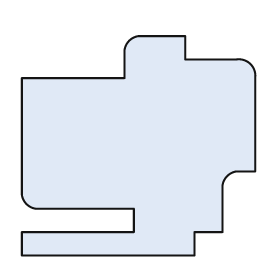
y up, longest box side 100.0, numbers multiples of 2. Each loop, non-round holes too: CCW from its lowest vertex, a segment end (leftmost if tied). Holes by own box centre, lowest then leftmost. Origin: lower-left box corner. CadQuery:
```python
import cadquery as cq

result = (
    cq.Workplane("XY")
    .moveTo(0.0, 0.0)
    .lineTo(74.0, 0.0)
    .lineTo(74.0, 10.0)
    .lineTo(86.0, 10.0)
    .lineTo(86.0, 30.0)
    .threePointArc((88.0, 34.0), (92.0, 36.0))
    .lineTo(100.0, 36.0)
    .lineTo(100.0, 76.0)
    .threePointArc((98.0, 82.0), (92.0, 84.0))
    .lineTo(70.0, 84.0)
    .lineTo(70.0, 94.0)
    .lineTo(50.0, 94.0)
    .threePointArc((46.0, 92.0), (44.0, 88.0))
    .lineTo(44.0, 76.0)
    .lineTo(0.0, 76.0)
    .lineTo(0.0, 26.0)
    .threePointArc((2.0, 22.0), (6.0, 20.0))
    .lineTo(48.0, 20.0)
    .lineTo(48.0, 10.0)
    .lineTo(0.0, 10.0)
    .close()
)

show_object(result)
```